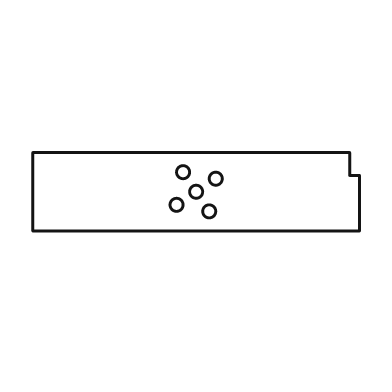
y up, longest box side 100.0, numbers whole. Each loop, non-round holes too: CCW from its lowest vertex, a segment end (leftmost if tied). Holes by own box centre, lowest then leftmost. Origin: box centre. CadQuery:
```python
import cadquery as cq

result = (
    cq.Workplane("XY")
    .moveTo(-50.0, -12.0)
    .lineTo(50.0, -12.0)
    .lineTo(50.0, 5.0)
    .lineTo(47.0, 5.0)
    .lineTo(47.0, 12.0)
    .lineTo(-50.0, 12.0)
    .close()
    .moveTo(4.0, -6.0)
    .circle(2.0)
    .moveTo(-6.0, -4.0)
    .circle(2.0)
    .moveTo(0.0, 0.0)
    .circle(2.0)
    .moveTo(6.0, 4.0)
    .circle(2.0)
    .moveTo(-4.0, 6.0)
    .circle(2.0)
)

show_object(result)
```